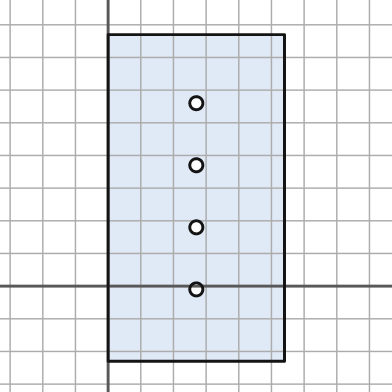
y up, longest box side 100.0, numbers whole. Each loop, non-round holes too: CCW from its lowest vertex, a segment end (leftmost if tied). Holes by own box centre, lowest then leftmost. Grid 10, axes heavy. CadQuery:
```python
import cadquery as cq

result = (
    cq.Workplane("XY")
    .moveTo(0.0, -23.0)
    .lineTo(54.0, -23.0)
    .lineTo(54.0, 77.0)
    .lineTo(0.0, 77.0)
    .close()
    .moveTo(27.0, -1.0)
    .circle(2.0)
    .moveTo(27.0, 18.0)
    .circle(2.0)
    .moveTo(27.0, 37.0)
    .circle(2.0)
    .moveTo(27.0, 56.0)
    .circle(2.0)
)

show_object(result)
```